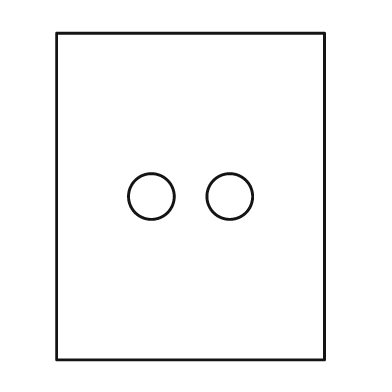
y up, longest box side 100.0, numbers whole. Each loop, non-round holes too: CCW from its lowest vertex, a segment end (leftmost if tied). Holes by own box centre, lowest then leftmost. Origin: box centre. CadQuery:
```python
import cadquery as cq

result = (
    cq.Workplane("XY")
    .moveTo(-41.0, -50.0)
    .lineTo(41.0, -50.0)
    .lineTo(41.0, 50.0)
    .lineTo(-41.0, 50.0)
    .close()
    .moveTo(-12.0, 0.0)
    .circle(7.0)
    .moveTo(12.0, 0.0)
    .circle(7.0)
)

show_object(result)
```